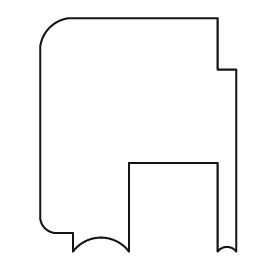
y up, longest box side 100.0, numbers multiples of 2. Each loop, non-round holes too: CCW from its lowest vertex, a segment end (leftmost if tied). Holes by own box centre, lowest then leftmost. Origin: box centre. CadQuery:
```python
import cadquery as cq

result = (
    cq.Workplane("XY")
    .moveTo(-28.0, -50.0)
    .threePointArc((-16.0, -44.0), (-4.0, -50.0))
    .lineTo(-4.0, -12.0)
    .lineTo(34.0, -12.0)
    .lineTo(34.0, -50.0)
    .threePointArc((38.0, -48.0), (42.0, -50.0))
    .lineTo(42.0, 28.0)
    .lineTo(34.0, 28.0)
    .lineTo(34.0, 50.0)
    .lineTo(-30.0, 50.0)
    .threePointArc((-38.0, 46.0), (-42.0, 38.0))
    .lineTo(-42.0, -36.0)
    .threePointArc((-40.0, -40.0), (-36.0, -42.0))
    .lineTo(-28.0, -42.0)
    .close()
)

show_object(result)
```